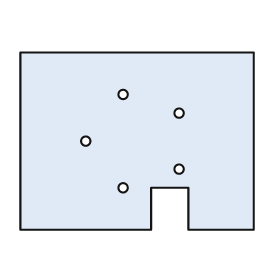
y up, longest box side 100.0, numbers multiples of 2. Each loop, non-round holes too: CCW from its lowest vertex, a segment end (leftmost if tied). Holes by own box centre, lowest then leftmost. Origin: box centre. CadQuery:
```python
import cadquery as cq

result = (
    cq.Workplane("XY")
    .moveTo(-50.0, -38.0)
    .lineTo(6.0, -38.0)
    .lineTo(6.0, -20.0)
    .lineTo(22.0, -20.0)
    .lineTo(22.0, -38.0)
    .lineTo(50.0, -38.0)
    .lineTo(50.0, 38.0)
    .lineTo(-50.0, 38.0)
    .close()
    .moveTo(-6.0, -20.0)
    .circle(2.0)
    .moveTo(18.0, -12.0)
    .circle(2.0)
    .moveTo(-22.0, 0.0)
    .circle(2.0)
    .moveTo(18.0, 12.0)
    .circle(2.0)
    .moveTo(-6.0, 20.0)
    .circle(2.0)
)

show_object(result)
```